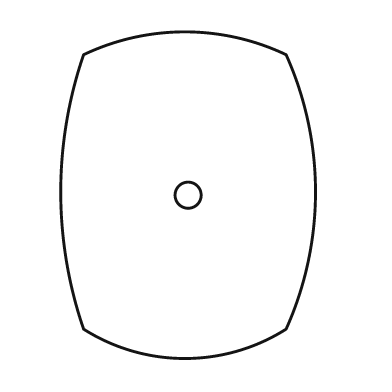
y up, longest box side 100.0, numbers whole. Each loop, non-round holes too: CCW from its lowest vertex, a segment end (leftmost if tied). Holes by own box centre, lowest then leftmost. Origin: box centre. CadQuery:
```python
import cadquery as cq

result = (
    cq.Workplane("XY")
    .moveTo(-32.0, -41.0)
    .threePointArc((-1.0, -50.0), (30.0, -41.0))
    .threePointArc((39.0, 1.0), (30.0, 43.0))
    .threePointArc((-1.0, 50.0), (-32.0, 43.0))
    .threePointArc((-39.0, 1.0), (-32.0, -41.0))
    .close()
    .moveTo(0.0, 0.0)
    .circle(4.0)
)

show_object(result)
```